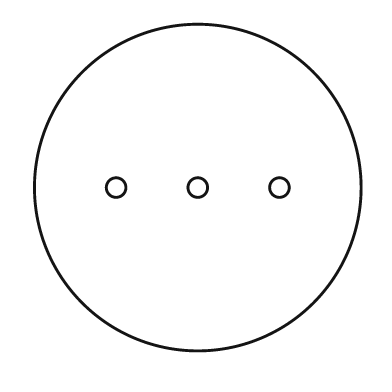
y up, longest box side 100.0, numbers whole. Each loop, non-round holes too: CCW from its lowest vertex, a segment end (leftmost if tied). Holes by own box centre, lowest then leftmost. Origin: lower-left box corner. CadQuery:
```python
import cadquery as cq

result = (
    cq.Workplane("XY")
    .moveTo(50.0, 50.0)
    .circle(50.0)
    .moveTo(25.0, 50.0)
    .circle(3.0)
    .moveTo(50.0, 50.0)
    .circle(3.0)
    .moveTo(75.0, 50.0)
    .circle(3.0)
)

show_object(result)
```